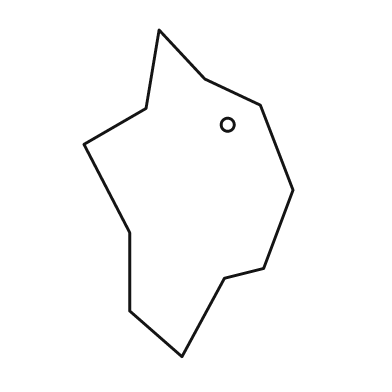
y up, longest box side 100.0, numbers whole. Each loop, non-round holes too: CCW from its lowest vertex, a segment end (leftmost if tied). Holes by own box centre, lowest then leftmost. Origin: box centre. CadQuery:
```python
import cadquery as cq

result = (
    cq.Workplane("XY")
    .moveTo(-2.0, -50.0)
    .lineTo(11.0, -26.0)
    .lineTo(23.0, -23.0)
    .lineTo(32.0, 1.0)
    .lineTo(22.0, 27.0)
    .lineTo(5.0, 35.0)
    .lineTo(-9.0, 50.0)
    .lineTo(-13.0, 26.0)
    .lineTo(-32.0, 15.0)
    .lineTo(-18.0, -12.0)
    .lineTo(-18.0, -36.0)
    .close()
    .moveTo(12.0, 21.0)
    .circle(2.0)
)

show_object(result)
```